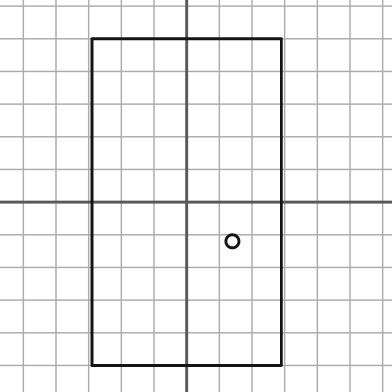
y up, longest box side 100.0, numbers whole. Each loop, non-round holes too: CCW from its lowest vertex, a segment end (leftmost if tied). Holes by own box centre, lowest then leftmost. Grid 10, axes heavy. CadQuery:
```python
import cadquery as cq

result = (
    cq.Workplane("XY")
    .moveTo(-29.0, -50.0)
    .lineTo(29.0, -50.0)
    .lineTo(29.0, 50.0)
    .lineTo(-29.0, 50.0)
    .close()
    .moveTo(14.0, -12.0)
    .circle(2.0)
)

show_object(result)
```